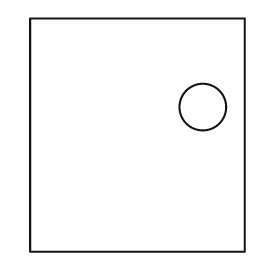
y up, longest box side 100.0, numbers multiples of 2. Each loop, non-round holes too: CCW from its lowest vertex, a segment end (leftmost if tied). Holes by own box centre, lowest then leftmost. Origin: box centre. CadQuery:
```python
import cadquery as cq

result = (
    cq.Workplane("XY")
    .moveTo(-46.0, -50.0)
    .lineTo(46.0, -50.0)
    .lineTo(46.0, 50.0)
    .lineTo(-46.0, 50.0)
    .close()
    .moveTo(28.0, 12.0)
    .circle(10.0)
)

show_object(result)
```